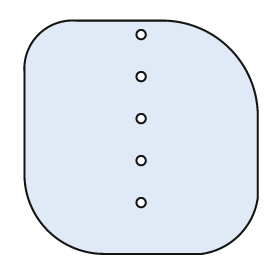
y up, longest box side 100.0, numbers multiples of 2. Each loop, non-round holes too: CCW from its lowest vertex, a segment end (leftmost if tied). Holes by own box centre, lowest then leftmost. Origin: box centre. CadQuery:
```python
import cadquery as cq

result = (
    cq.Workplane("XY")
    .moveTo(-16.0, -50.0)
    .lineTo(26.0, -50.0)
    .threePointArc((42.0, -42.0), (50.0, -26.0))
    .lineTo(50.0, 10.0)
    .threePointArc((38.0, 38.0), (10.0, 50.0))
    .lineTo(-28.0, 50.0)
    .threePointArc((-44.0, 44.0), (-50.0, 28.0))
    .lineTo(-50.0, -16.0)
    .threePointArc((-40.0, -40.0), (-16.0, -50.0))
    .close()
    .moveTo(0.0, -28.0)
    .circle(2.0)
    .moveTo(0.0, -10.0)
    .circle(2.0)
    .moveTo(0.0, 8.0)
    .circle(2.0)
    .moveTo(0.0, 26.0)
    .circle(2.0)
    .moveTo(0.0, 44.0)
    .circle(2.0)
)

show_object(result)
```